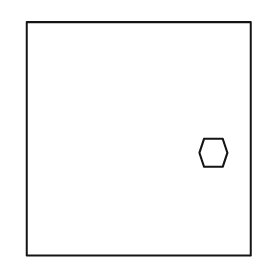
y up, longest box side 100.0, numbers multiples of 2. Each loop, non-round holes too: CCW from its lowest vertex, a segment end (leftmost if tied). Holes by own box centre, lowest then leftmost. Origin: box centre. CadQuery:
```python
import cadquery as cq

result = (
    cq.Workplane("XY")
    .moveTo(-48.0, -50.0)
    .lineTo(48.0, -50.0)
    .lineTo(48.0, 50.0)
    .lineTo(-48.0, 50.0)
    .close()
    .moveTo(28.0, -12.0)
    .lineTo(36.0, -12.0)
    .lineTo(38.0, -6.0)
    .lineTo(36.0, 0.0)
    .lineTo(28.0, 0.0)
    .lineTo(26.0, -6.0)
    .close()
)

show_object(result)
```